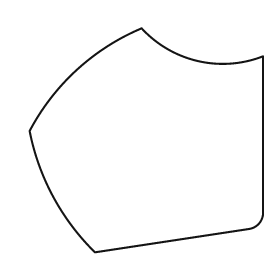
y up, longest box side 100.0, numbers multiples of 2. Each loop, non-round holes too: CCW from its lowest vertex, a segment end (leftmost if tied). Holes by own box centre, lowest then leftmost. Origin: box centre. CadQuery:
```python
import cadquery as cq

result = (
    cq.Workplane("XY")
    .moveTo(-22.0, -48.0)
    .lineTo(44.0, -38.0)
    .threePointArc((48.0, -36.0), (50.0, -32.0))
    .lineTo(50.0, 36.0)
    .threePointArc((22.0, 34.0), (-2.0, 48.0))
    .threePointArc((-30.0, 30.0), (-50.0, 4.0))
    .threePointArc((-40.0, -24.0), (-22.0, -48.0))
    .close()
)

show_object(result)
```